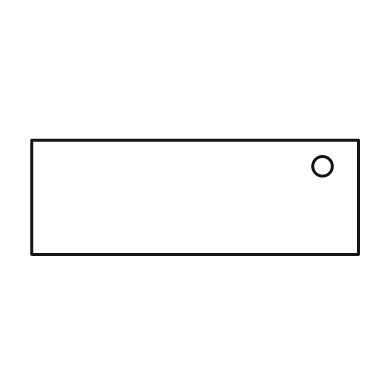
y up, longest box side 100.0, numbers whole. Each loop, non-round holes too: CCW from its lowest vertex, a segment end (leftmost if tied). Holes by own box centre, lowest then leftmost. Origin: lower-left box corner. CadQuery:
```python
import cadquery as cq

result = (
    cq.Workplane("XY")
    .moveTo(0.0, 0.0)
    .lineTo(100.0, 0.0)
    .lineTo(100.0, 35.0)
    .lineTo(0.0, 35.0)
    .close()
    .moveTo(89.0, 27.0)
    .circle(3.0)
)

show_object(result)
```